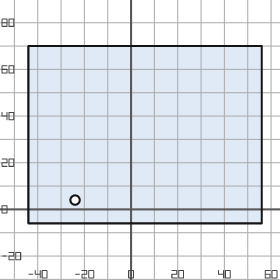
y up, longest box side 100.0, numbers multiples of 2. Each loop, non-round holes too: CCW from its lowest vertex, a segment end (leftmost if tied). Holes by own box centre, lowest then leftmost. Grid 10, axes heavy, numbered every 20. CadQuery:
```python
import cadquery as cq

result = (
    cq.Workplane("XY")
    .moveTo(-44.0, -6.0)
    .lineTo(56.0, -6.0)
    .lineTo(56.0, 70.0)
    .lineTo(-44.0, 70.0)
    .close()
    .moveTo(-24.0, 4.0)
    .circle(2.0)
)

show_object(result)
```